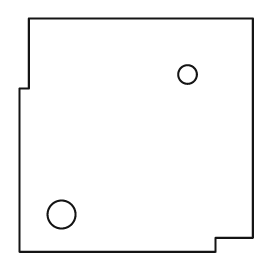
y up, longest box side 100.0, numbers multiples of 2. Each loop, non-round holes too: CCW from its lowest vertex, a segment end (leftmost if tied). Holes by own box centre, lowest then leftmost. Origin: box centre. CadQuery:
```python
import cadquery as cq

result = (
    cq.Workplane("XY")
    .moveTo(-50.0, -50.0)
    .lineTo(34.0, -50.0)
    .lineTo(34.0, -44.0)
    .lineTo(50.0, -44.0)
    .lineTo(50.0, 50.0)
    .lineTo(-46.0, 50.0)
    .lineTo(-46.0, 20.0)
    .lineTo(-50.0, 20.0)
    .close()
    .moveTo(-32.0, -34.0)
    .circle(6.0)
    .moveTo(22.0, 26.0)
    .circle(4.0)
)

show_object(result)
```